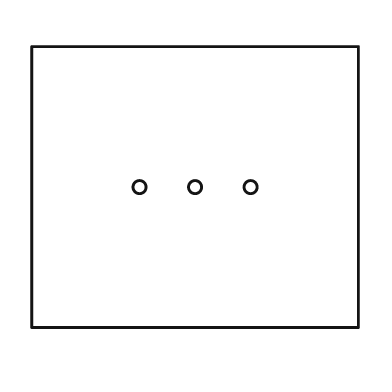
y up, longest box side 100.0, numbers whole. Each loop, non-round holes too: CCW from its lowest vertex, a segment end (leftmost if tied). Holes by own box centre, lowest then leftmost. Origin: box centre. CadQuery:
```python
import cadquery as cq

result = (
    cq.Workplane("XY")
    .moveTo(-50.0, -43.0)
    .lineTo(50.0, -43.0)
    .lineTo(50.0, 43.0)
    .lineTo(-50.0, 43.0)
    .close()
    .moveTo(-17.0, 0.0)
    .circle(2.0)
    .moveTo(0.0, 0.0)
    .circle(2.0)
    .moveTo(17.0, 0.0)
    .circle(2.0)
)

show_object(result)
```